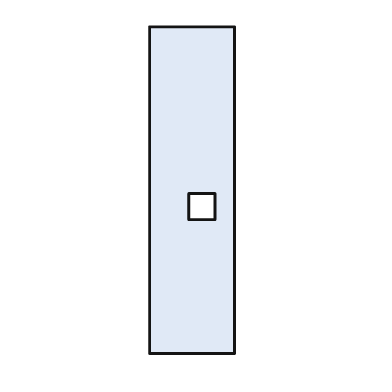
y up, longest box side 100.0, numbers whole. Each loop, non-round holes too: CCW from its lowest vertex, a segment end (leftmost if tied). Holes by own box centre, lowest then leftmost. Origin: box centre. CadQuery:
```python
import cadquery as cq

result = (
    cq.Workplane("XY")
    .moveTo(-13.0, -50.0)
    .lineTo(13.0, -50.0)
    .lineTo(13.0, 50.0)
    .lineTo(-13.0, 50.0)
    .close()
    .moveTo(-1.0, -9.0)
    .lineTo(7.0, -9.0)
    .lineTo(7.0, -1.0)
    .lineTo(-1.0, -1.0)
    .close()
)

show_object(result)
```